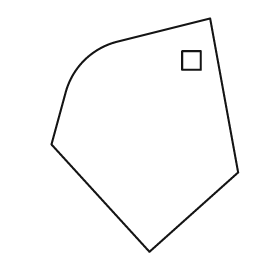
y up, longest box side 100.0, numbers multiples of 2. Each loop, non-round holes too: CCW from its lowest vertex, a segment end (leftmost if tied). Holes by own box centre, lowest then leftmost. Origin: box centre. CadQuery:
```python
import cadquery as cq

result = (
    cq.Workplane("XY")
    .moveTo(2.0, -50.0)
    .lineTo(40.0, -16.0)
    .lineTo(28.0, 50.0)
    .lineTo(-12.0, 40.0)
    .threePointArc((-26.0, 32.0), (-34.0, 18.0))
    .lineTo(-40.0, -4.0)
    .close()
    .moveTo(16.0, 28.0)
    .lineTo(24.0, 28.0)
    .lineTo(24.0, 36.0)
    .lineTo(16.0, 36.0)
    .close()
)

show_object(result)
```